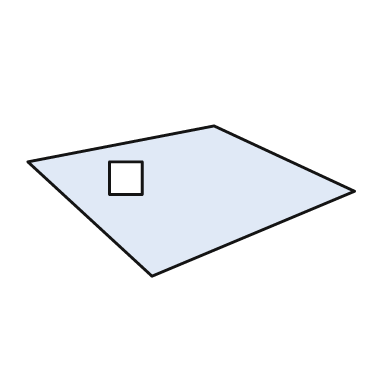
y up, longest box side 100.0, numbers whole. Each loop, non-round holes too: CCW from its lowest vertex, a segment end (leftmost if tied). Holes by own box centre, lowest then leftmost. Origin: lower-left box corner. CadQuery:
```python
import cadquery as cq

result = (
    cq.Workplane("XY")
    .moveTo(38.0, 0.0)
    .lineTo(100.0, 26.0)
    .lineTo(57.0, 46.0)
    .lineTo(0.0, 35.0)
    .close()
    .moveTo(25.0, 25.0)
    .lineTo(35.0, 25.0)
    .lineTo(35.0, 35.0)
    .lineTo(25.0, 35.0)
    .close()
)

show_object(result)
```